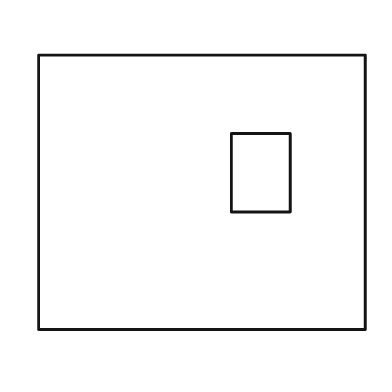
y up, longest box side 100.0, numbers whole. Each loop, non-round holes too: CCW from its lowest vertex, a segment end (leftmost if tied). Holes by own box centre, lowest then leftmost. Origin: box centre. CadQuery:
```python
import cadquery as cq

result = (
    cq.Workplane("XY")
    .moveTo(-50.0, -42.0)
    .lineTo(50.0, -42.0)
    .lineTo(50.0, 42.0)
    .lineTo(-50.0, 42.0)
    .close()
    .moveTo(9.0, -6.0)
    .lineTo(27.0, -6.0)
    .lineTo(27.0, 18.0)
    .lineTo(9.0, 18.0)
    .close()
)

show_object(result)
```